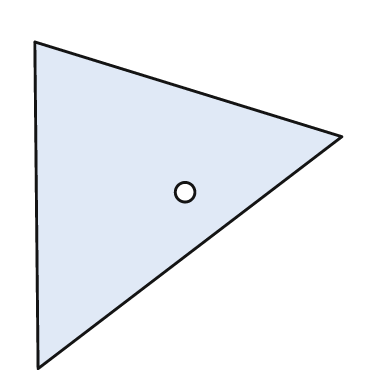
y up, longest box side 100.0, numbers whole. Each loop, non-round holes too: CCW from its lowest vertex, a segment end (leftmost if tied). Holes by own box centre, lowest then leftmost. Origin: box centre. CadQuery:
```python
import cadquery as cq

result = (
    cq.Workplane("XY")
    .moveTo(-46.0, -50.0)
    .lineTo(47.0, 21.0)
    .lineTo(-47.0, 50.0)
    .close()
    .moveTo(-1.0, 4.0)
    .circle(3.0)
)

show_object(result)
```